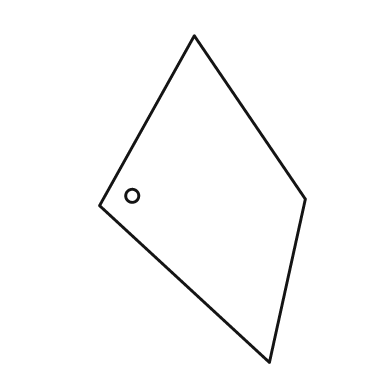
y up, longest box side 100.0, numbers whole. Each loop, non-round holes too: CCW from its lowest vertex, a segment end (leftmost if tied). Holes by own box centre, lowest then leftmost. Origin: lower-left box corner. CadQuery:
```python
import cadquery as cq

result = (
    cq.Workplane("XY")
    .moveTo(52.0, 0.0)
    .lineTo(63.0, 50.0)
    .lineTo(29.0, 100.0)
    .lineTo(0.0, 48.0)
    .close()
    .moveTo(10.0, 51.0)
    .circle(2.0)
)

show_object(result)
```